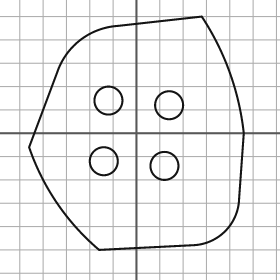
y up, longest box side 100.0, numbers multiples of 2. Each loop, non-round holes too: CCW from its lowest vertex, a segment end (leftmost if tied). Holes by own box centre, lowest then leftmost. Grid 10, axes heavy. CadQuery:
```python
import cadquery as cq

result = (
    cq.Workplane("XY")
    .moveTo(-16.0, -50.0)
    .lineTo(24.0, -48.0)
    .threePointArc((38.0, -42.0), (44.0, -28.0))
    .lineTo(46.0, 0.0)
    .threePointArc((40.0, 26.0), (28.0, 50.0))
    .lineTo(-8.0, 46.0)
    .threePointArc((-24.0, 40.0), (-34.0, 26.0))
    .lineTo(-46.0, -6.0)
    .threePointArc((-34.0, -30.0), (-16.0, -50.0))
    .close()
    .moveTo(12.0, -14.0)
    .circle(6.0)
    .moveTo(-14.0, -12.0)
    .circle(6.0)
    .moveTo(14.0, 12.0)
    .circle(6.0)
    .moveTo(-12.0, 14.0)
    .circle(6.0)
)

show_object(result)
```